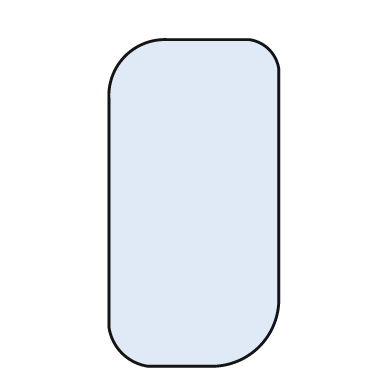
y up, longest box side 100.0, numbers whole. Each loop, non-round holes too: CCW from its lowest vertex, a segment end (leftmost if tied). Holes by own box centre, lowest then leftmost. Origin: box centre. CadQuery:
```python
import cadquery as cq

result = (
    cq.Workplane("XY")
    .moveTo(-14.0, -50.0)
    .lineTo(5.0, -50.0)
    .threePointArc((20.0, -44.0), (26.0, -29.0))
    .lineTo(26.0, 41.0)
    .threePointArc((23.0, 47.0), (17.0, 50.0))
    .lineTo(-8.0, 50.0)
    .threePointArc((-21.0, 45.0), (-26.0, 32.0))
    .lineTo(-26.0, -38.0)
    .threePointArc((-22.0, -46.0), (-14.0, -50.0))
    .close()
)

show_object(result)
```